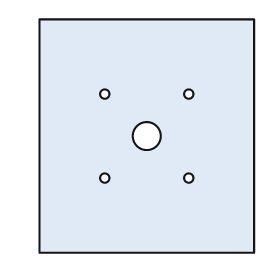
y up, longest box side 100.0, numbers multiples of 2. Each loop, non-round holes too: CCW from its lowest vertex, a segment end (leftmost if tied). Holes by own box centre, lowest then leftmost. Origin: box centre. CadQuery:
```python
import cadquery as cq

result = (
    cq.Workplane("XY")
    .moveTo(-46.0, -50.0)
    .lineTo(46.0, -50.0)
    .lineTo(46.0, 50.0)
    .lineTo(-46.0, 50.0)
    .close()
    .moveTo(-18.0, -18.0)
    .circle(2.0)
    .moveTo(18.0, -18.0)
    .circle(2.0)
    .moveTo(0.0, 0.0)
    .circle(6.0)
    .moveTo(-18.0, 18.0)
    .circle(2.0)
    .moveTo(18.0, 18.0)
    .circle(2.0)
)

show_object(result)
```